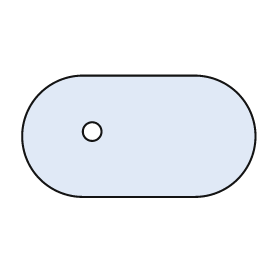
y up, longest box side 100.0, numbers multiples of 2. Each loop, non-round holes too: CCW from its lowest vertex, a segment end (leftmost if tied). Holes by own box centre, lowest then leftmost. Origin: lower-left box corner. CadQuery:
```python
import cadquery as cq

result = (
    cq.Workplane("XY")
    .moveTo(26.0, 0.0)
    .lineTo(74.0, 0.0)
    .threePointArc((100.0, 26.0), (74.0, 52.0))
    .lineTo(26.0, 52.0)
    .threePointArc((0.0, 26.0), (26.0, 0.0))
    .close()
    .moveTo(30.0, 28.0)
    .circle(4.0)
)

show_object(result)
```